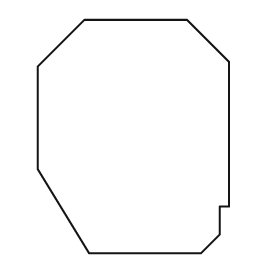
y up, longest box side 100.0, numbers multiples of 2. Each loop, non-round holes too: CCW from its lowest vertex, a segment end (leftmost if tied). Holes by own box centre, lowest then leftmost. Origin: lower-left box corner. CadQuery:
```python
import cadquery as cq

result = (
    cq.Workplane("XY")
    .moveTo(22.0, 0.0)
    .lineTo(70.0, 0.0)
    .lineTo(78.0, 8.0)
    .lineTo(78.0, 20.0)
    .lineTo(82.0, 20.0)
    .lineTo(82.0, 82.0)
    .lineTo(64.0, 100.0)
    .lineTo(20.0, 100.0)
    .lineTo(0.0, 80.0)
    .lineTo(0.0, 36.0)
    .close()
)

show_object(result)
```